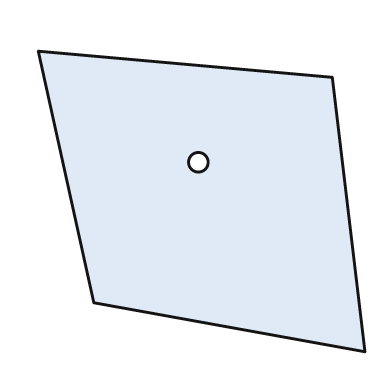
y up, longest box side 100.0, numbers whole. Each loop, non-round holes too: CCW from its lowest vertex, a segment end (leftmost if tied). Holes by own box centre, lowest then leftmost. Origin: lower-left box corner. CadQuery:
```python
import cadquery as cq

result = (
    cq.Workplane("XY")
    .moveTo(100.0, 0.0)
    .lineTo(90.0, 84.0)
    .lineTo(0.0, 92.0)
    .lineTo(17.0, 15.0)
    .close()
    .moveTo(49.0, 58.0)
    .circle(3.0)
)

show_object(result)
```